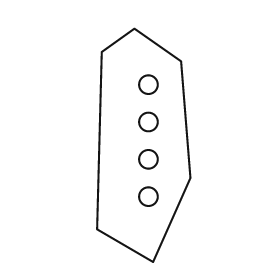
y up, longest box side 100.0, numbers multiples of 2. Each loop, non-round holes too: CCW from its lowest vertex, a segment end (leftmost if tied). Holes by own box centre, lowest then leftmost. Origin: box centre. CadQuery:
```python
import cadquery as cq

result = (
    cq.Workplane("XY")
    .moveTo(4.0, -50.0)
    .lineTo(20.0, -14.0)
    .lineTo(16.0, 36.0)
    .lineTo(-4.0, 50.0)
    .lineTo(-18.0, 40.0)
    .lineTo(-20.0, -36.0)
    .close()
    .moveTo(2.0, -22.0)
    .circle(4.0)
    .moveTo(2.0, -6.0)
    .circle(4.0)
    .moveTo(2.0, 10.0)
    .circle(4.0)
    .moveTo(2.0, 26.0)
    .circle(4.0)
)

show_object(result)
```